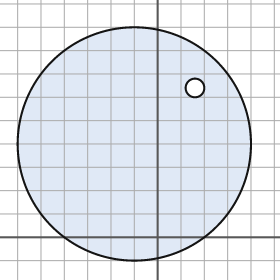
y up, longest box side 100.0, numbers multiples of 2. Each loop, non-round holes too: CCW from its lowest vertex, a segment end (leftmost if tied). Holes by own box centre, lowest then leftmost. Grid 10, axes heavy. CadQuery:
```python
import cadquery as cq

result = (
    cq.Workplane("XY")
    .moveTo(-10.0, 40.0)
    .circle(50.0)
    .moveTo(16.0, 64.0)
    .circle(4.0)
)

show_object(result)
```